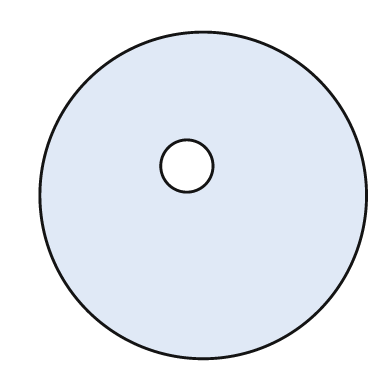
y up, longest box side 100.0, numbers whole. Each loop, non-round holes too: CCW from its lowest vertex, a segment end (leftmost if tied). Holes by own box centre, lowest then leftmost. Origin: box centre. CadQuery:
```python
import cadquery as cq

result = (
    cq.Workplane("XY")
    .moveTo(0.0, 0.0)
    .circle(50.0)
    .moveTo(-5.0, 9.0)
    .circle(8.0)
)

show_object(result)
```